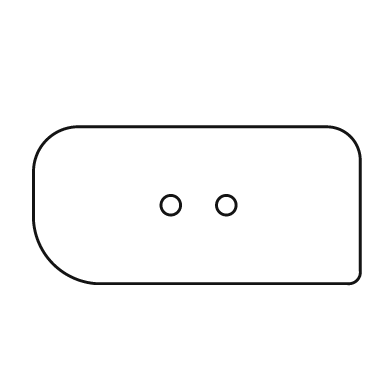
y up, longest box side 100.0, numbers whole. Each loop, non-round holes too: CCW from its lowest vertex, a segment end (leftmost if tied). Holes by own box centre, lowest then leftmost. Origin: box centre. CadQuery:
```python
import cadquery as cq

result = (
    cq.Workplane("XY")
    .moveTo(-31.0, -24.0)
    .lineTo(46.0, -24.0)
    .threePointArc((49.0, -23.0), (50.0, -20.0))
    .lineTo(50.0, 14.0)
    .threePointArc((47.0, 21.0), (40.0, 24.0))
    .lineTo(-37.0, 24.0)
    .threePointArc((-46.0, 20.0), (-50.0, 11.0))
    .lineTo(-50.0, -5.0)
    .threePointArc((-44.0, -18.0), (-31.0, -24.0))
    .close()
    .moveTo(-8.0, 0.0)
    .circle(3.0)
    .moveTo(9.0, 0.0)
    .circle(3.0)
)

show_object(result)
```